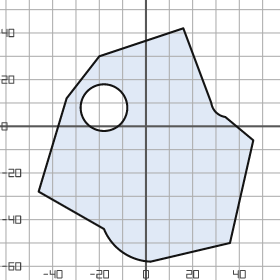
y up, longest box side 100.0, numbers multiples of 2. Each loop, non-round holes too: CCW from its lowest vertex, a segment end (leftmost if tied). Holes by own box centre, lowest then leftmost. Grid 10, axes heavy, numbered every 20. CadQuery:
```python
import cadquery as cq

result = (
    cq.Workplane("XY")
    .moveTo(2.0, -58.0)
    .lineTo(36.0, -50.0)
    .lineTo(46.0, -6.0)
    .lineTo(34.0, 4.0)
    .threePointArc((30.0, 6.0), (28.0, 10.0))
    .lineTo(16.0, 42.0)
    .lineTo(-20.0, 30.0)
    .lineTo(-34.0, 12.0)
    .lineTo(-46.0, -28.0)
    .lineTo(-18.0, -44.0)
    .threePointArc((-10.0, -54.0), (2.0, -58.0))
    .close()
    .moveTo(-18.0, 8.0)
    .circle(10.0)
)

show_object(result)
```